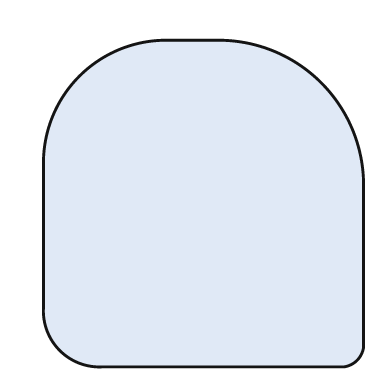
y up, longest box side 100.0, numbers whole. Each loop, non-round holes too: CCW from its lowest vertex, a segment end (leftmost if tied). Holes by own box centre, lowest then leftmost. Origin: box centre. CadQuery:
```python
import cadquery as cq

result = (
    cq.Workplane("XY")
    .moveTo(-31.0, -50.0)
    .lineTo(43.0, -50.0)
    .threePointArc((47.0, -48.0), (49.0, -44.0))
    .lineTo(49.0, 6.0)
    .threePointArc((36.0, 37.0), (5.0, 50.0))
    .lineTo(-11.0, 50.0)
    .threePointArc((-38.0, 39.0), (-49.0, 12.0))
    .lineTo(-49.0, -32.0)
    .threePointArc((-44.0, -45.0), (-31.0, -50.0))
    .close()
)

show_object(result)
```